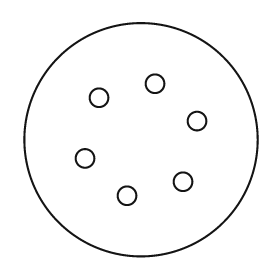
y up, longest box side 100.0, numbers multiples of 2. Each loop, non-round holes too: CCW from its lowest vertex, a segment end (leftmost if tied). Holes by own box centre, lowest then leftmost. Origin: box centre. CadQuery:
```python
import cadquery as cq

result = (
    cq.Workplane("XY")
    .moveTo(0.0, 0.0)
    .circle(50.0)
    .moveTo(-6.0, -24.0)
    .circle(4.0)
    .moveTo(18.0, -18.0)
    .circle(4.0)
    .moveTo(-24.0, -8.0)
    .circle(4.0)
    .moveTo(24.0, 8.0)
    .circle(4.0)
    .moveTo(-18.0, 18.0)
    .circle(4.0)
    .moveTo(6.0, 24.0)
    .circle(4.0)
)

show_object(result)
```